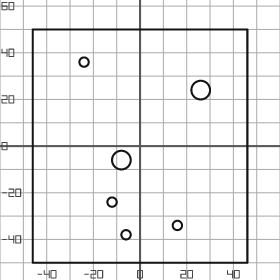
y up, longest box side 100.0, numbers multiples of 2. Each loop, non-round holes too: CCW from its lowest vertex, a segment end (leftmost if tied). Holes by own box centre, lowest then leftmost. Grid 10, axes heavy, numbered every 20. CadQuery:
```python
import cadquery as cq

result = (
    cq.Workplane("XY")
    .moveTo(-46.0, -50.0)
    .lineTo(46.0, -50.0)
    .lineTo(46.0, 50.0)
    .lineTo(-46.0, 50.0)
    .close()
    .moveTo(-6.0, -38.0)
    .circle(2.0)
    .moveTo(16.0, -34.0)
    .circle(2.0)
    .moveTo(-12.0, -24.0)
    .circle(2.0)
    .moveTo(-8.0, -6.0)
    .circle(4.0)
    .moveTo(26.0, 24.0)
    .circle(4.0)
    .moveTo(-24.0, 36.0)
    .circle(2.0)
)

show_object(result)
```